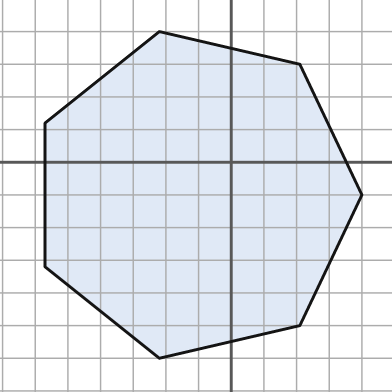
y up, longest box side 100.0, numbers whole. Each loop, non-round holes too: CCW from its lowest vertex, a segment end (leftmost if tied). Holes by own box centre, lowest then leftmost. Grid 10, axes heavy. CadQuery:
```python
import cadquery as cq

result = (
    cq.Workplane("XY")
    .moveTo(-22.0, -60.0)
    .lineTo(21.0, -50.0)
    .lineTo(40.0, -10.0)
    .lineTo(21.0, 30.0)
    .lineTo(-22.0, 40.0)
    .lineTo(-57.0, 12.0)
    .lineTo(-57.0, -32.0)
    .close()
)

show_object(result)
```